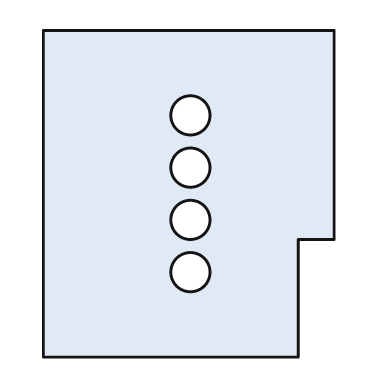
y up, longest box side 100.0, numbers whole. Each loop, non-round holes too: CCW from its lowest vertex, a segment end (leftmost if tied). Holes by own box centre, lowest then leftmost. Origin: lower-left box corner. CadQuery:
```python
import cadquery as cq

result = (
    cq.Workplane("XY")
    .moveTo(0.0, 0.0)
    .lineTo(78.0, 0.0)
    .lineTo(78.0, 36.0)
    .lineTo(89.0, 36.0)
    .lineTo(89.0, 100.0)
    .lineTo(0.0, 100.0)
    .close()
    .moveTo(45.0, 26.0)
    .circle(6.0)
    .moveTo(45.0, 42.0)
    .circle(6.0)
    .moveTo(45.0, 58.0)
    .circle(6.0)
    .moveTo(45.0, 74.0)
    .circle(6.0)
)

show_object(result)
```